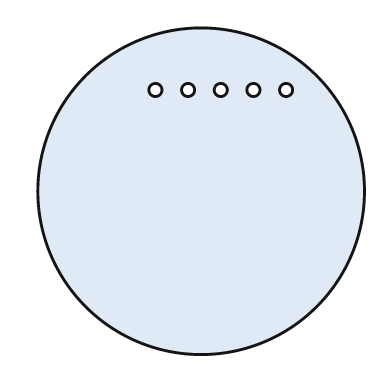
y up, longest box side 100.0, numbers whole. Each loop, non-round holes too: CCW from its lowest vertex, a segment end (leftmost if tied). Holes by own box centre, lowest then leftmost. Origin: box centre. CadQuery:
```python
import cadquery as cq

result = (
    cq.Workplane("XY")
    .moveTo(0.0, 0.0)
    .circle(50.0)
    .moveTo(-14.0, 31.0)
    .circle(2.0)
    .moveTo(-4.0, 31.0)
    .circle(2.0)
    .moveTo(6.0, 31.0)
    .circle(2.0)
    .moveTo(16.0, 31.0)
    .circle(2.0)
    .moveTo(26.0, 31.0)
    .circle(2.0)
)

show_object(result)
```